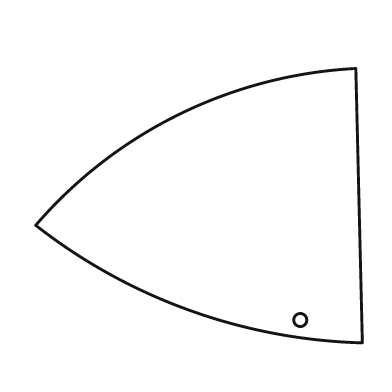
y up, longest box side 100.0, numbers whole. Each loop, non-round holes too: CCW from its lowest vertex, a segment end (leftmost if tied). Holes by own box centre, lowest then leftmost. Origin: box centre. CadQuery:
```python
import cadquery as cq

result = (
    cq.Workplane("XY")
    .moveTo(50.0, -42.0)
    .lineTo(48.0, 42.0)
    .threePointArc((-6.0, 28.0), (-50.0, -6.0))
    .threePointArc((-3.0, -32.0), (50.0, -42.0))
    .close()
    .moveTo(31.0, -35.0)
    .circle(2.0)
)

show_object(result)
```